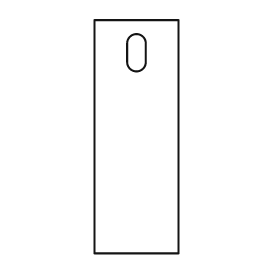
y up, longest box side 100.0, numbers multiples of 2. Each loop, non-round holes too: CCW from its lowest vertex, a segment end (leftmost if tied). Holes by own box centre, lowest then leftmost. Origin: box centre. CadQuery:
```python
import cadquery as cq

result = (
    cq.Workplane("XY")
    .moveTo(-18.0, -50.0)
    .lineTo(18.0, -50.0)
    .lineTo(18.0, 50.0)
    .lineTo(-18.0, 50.0)
    .close()
    .moveTo(-4.0, 32.0)
    .threePointArc((0.0, 28.0), (4.0, 32.0))
    .lineTo(4.0, 40.0)
    .threePointArc((0.0, 44.0), (-4.0, 40.0))
    .close()
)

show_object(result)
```